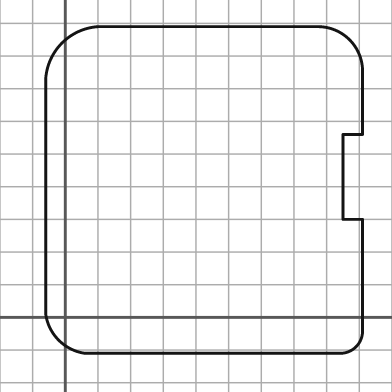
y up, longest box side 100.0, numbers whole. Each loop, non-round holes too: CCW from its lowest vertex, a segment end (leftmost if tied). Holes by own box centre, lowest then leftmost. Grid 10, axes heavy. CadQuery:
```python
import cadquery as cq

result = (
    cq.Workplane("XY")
    .moveTo(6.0, -11.0)
    .lineTo(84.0, -11.0)
    .threePointArc((89.0, -9.0), (91.0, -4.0))
    .lineTo(91.0, 30.0)
    .lineTo(85.0, 30.0)
    .lineTo(85.0, 56.0)
    .lineTo(91.0, 56.0)
    .lineTo(91.0, 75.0)
    .threePointArc((87.0, 85.0), (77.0, 89.0))
    .lineTo(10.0, 89.0)
    .threePointArc((-1.0, 84.0), (-6.0, 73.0))
    .lineTo(-6.0, 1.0)
    .threePointArc((-2.0, -7.0), (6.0, -11.0))
    .close()
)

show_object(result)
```